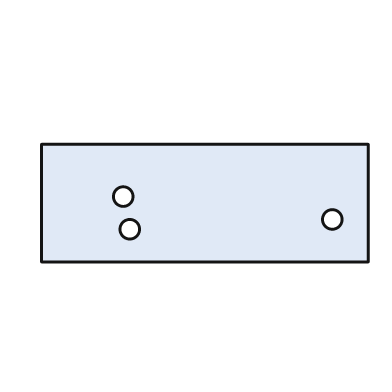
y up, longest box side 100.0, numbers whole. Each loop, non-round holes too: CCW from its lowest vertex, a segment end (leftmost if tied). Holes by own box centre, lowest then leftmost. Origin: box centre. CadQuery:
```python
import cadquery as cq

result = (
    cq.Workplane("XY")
    .moveTo(-50.0, -18.0)
    .lineTo(50.0, -18.0)
    .lineTo(50.0, 18.0)
    .lineTo(-50.0, 18.0)
    .close()
    .moveTo(-23.0, -8.0)
    .circle(3.0)
    .moveTo(39.0, -5.0)
    .circle(3.0)
    .moveTo(-25.0, 2.0)
    .circle(3.0)
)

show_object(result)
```